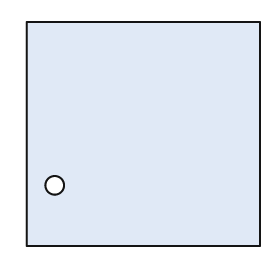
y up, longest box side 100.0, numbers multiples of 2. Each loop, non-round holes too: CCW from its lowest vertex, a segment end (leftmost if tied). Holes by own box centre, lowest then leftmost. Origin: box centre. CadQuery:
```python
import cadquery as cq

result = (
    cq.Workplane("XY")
    .moveTo(-50.0, -48.0)
    .lineTo(50.0, -48.0)
    .lineTo(50.0, 48.0)
    .lineTo(-50.0, 48.0)
    .close()
    .moveTo(-38.0, -22.0)
    .circle(4.0)
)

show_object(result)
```